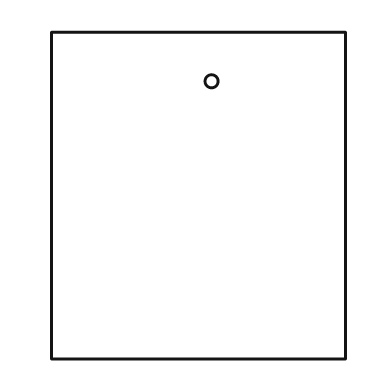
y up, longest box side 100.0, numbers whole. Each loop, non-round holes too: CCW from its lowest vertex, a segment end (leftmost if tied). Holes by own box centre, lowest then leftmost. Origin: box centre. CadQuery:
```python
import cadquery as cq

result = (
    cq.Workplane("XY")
    .moveTo(-45.0, -50.0)
    .lineTo(45.0, -50.0)
    .lineTo(45.0, 50.0)
    .lineTo(-45.0, 50.0)
    .close()
    .moveTo(4.0, 35.0)
    .circle(2.0)
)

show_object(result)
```